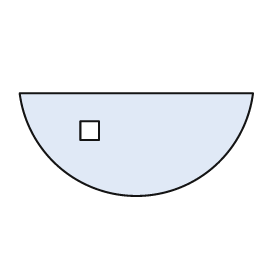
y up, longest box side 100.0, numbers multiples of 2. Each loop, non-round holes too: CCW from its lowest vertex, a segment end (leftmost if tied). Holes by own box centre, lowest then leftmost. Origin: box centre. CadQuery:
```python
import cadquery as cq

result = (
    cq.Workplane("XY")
    .moveTo(-50.0, 22.0)
    .threePointArc((0.0, -22.0), (50.0, 22.0))
    .close()
    .moveTo(-24.0, 2.0)
    .lineTo(-16.0, 2.0)
    .lineTo(-16.0, 10.0)
    .lineTo(-24.0, 10.0)
    .close()
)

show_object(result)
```